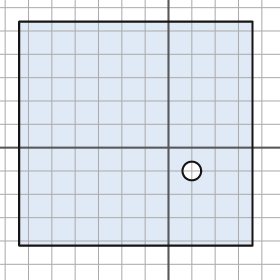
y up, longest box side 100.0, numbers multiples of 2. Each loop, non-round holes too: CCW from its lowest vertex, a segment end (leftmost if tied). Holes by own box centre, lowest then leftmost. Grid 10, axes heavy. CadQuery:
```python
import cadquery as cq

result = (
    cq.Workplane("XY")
    .moveTo(-64.0, -42.0)
    .lineTo(36.0, -42.0)
    .lineTo(36.0, 54.0)
    .lineTo(-64.0, 54.0)
    .close()
    .moveTo(10.0, -10.0)
    .circle(4.0)
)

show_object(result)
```